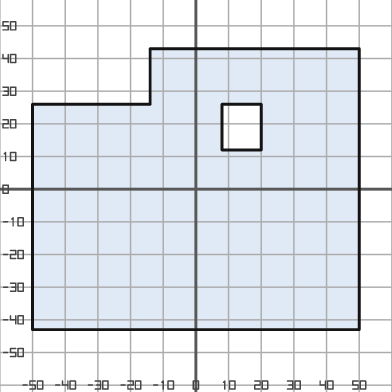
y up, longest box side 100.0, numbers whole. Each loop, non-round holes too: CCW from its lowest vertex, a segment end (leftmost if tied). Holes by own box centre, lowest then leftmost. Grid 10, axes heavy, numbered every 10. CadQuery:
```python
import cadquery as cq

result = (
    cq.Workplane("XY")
    .moveTo(-50.0, -43.0)
    .lineTo(50.0, -43.0)
    .lineTo(50.0, 43.0)
    .lineTo(-14.0, 43.0)
    .lineTo(-14.0, 26.0)
    .lineTo(-50.0, 26.0)
    .close()
    .moveTo(8.0, 12.0)
    .lineTo(20.0, 12.0)
    .lineTo(20.0, 26.0)
    .lineTo(8.0, 26.0)
    .close()
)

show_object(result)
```